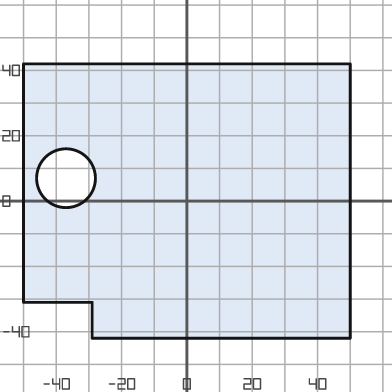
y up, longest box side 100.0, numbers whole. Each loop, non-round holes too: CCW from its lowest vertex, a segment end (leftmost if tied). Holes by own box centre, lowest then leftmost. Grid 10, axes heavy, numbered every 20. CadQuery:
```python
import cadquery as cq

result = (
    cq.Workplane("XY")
    .moveTo(-29.0, -42.0)
    .lineTo(50.0, -42.0)
    .lineTo(50.0, 42.0)
    .lineTo(-50.0, 42.0)
    .lineTo(-50.0, -31.0)
    .lineTo(-29.0, -31.0)
    .close()
    .moveTo(-37.0, 7.0)
    .circle(9.0)
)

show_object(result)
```